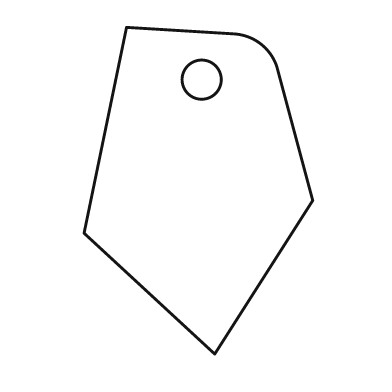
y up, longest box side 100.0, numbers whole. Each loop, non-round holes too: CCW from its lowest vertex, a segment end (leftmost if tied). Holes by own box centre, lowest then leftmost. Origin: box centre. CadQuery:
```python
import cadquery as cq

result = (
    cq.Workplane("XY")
    .moveTo(5.0, -50.0)
    .lineTo(35.0, -3.0)
    .lineTo(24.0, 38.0)
    .threePointArc((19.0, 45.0), (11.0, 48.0))
    .lineTo(-22.0, 50.0)
    .lineTo(-35.0, -13.0)
    .close()
    .moveTo(1.0, 34.0)
    .circle(6.0)
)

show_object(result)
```